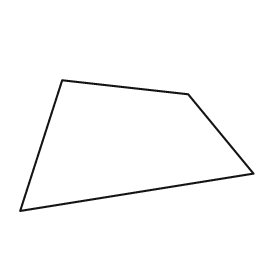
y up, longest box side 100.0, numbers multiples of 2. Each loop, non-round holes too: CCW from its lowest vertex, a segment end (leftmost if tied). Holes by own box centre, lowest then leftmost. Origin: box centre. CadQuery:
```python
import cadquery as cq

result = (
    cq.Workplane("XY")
    .moveTo(-50.0, -28.0)
    .lineTo(50.0, -12.0)
    .lineTo(22.0, 22.0)
    .lineTo(-32.0, 28.0)
    .close()
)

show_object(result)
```